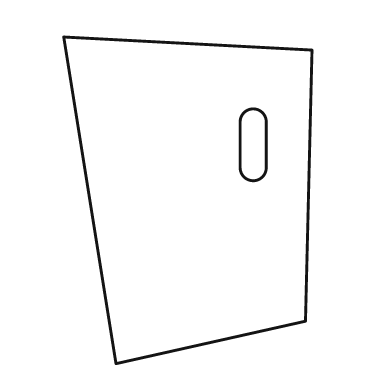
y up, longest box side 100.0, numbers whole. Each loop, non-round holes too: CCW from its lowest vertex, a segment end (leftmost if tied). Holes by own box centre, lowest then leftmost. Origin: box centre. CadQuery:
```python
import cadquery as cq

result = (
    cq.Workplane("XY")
    .moveTo(-22.0, -50.0)
    .lineTo(36.0, -37.0)
    .lineTo(38.0, 46.0)
    .lineTo(-38.0, 50.0)
    .close()
    .moveTo(16.0, 10.0)
    .threePointArc((20.0, 6.0), (24.0, 10.0))
    .lineTo(24.0, 24.0)
    .threePointArc((20.0, 28.0), (16.0, 24.0))
    .close()
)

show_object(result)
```